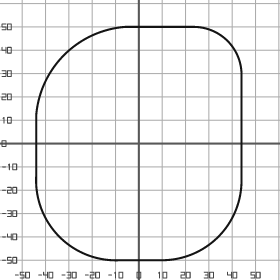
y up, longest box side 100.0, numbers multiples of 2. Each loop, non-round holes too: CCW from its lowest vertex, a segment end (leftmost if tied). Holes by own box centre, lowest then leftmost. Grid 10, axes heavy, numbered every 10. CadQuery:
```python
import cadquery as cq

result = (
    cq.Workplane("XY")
    .moveTo(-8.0, -50.0)
    .lineTo(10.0, -50.0)
    .threePointArc((34.0, -40.0), (44.0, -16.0))
    .lineTo(44.0, 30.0)
    .threePointArc((38.0, 44.0), (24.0, 50.0))
    .lineTo(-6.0, 50.0)
    .threePointArc((-32.0, 38.0), (-44.0, 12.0))
    .lineTo(-44.0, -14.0)
    .threePointArc((-34.0, -40.0), (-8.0, -50.0))
    .close()
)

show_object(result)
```